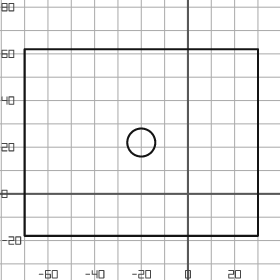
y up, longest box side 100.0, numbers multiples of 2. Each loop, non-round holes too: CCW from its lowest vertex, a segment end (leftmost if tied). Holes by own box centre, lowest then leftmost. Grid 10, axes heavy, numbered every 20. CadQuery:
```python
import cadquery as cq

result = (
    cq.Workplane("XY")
    .moveTo(-70.0, -18.0)
    .lineTo(30.0, -18.0)
    .lineTo(30.0, 62.0)
    .lineTo(-70.0, 62.0)
    .close()
    .moveTo(-20.0, 22.0)
    .circle(6.0)
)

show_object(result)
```